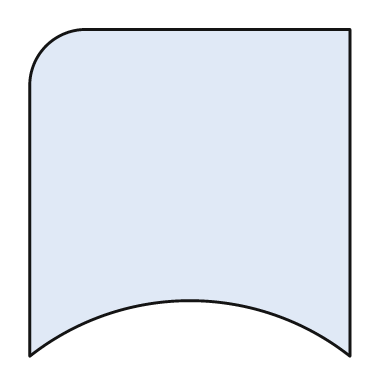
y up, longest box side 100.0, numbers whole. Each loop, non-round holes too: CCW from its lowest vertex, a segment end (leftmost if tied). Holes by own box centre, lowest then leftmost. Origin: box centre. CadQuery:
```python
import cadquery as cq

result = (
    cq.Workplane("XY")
    .moveTo(-49.0, -50.0)
    .threePointArc((0.0, -33.0), (49.0, -50.0))
    .lineTo(49.0, 50.0)
    .lineTo(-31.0, 50.0)
    .threePointArc((-44.0, 45.0), (-49.0, 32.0))
    .close()
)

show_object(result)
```